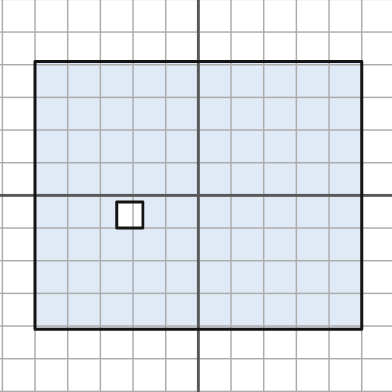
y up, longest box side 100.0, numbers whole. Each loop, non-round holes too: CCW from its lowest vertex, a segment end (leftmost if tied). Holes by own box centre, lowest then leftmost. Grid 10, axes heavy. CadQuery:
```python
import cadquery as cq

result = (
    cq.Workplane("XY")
    .moveTo(-50.0, -41.0)
    .lineTo(50.0, -41.0)
    .lineTo(50.0, 41.0)
    .lineTo(-50.0, 41.0)
    .close()
    .moveTo(-25.0, -10.0)
    .lineTo(-17.0, -10.0)
    .lineTo(-17.0, -2.0)
    .lineTo(-25.0, -2.0)
    .close()
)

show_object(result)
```